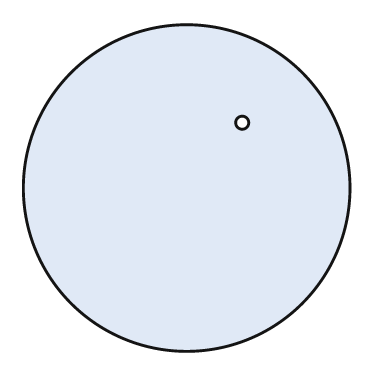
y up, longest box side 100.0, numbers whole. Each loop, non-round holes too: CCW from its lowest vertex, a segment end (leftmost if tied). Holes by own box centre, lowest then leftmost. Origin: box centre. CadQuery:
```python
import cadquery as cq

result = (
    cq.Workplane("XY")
    .moveTo(0.0, 0.0)
    .circle(50.0)
    .moveTo(17.0, 20.0)
    .circle(2.0)
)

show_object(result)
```